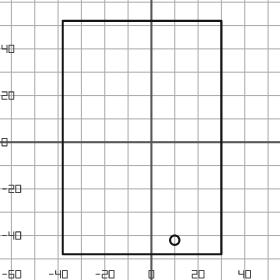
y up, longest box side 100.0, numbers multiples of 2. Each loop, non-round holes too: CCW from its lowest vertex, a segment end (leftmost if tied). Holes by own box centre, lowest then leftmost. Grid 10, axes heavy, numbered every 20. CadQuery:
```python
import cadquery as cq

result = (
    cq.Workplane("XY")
    .moveTo(-38.0, -48.0)
    .lineTo(30.0, -48.0)
    .lineTo(30.0, 52.0)
    .lineTo(-38.0, 52.0)
    .close()
    .moveTo(10.0, -42.0)
    .circle(2.0)
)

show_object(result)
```